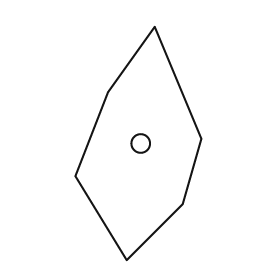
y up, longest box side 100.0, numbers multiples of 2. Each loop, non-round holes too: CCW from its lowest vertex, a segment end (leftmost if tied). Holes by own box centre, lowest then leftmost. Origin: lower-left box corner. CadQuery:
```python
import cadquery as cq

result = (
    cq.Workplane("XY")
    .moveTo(22.0, 0.0)
    .lineTo(46.0, 24.0)
    .lineTo(54.0, 52.0)
    .lineTo(34.0, 100.0)
    .lineTo(14.0, 72.0)
    .lineTo(0.0, 36.0)
    .close()
    .moveTo(28.0, 50.0)
    .circle(4.0)
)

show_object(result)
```